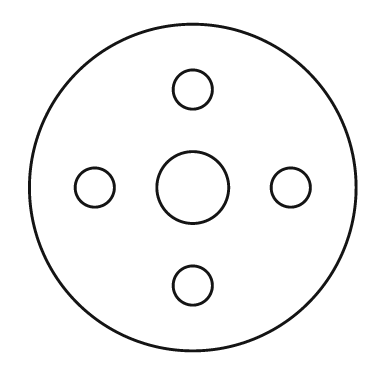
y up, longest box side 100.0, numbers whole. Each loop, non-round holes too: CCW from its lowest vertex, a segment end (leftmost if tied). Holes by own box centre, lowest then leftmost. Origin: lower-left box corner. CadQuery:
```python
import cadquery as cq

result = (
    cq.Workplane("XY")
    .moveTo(50.0, 50.0)
    .circle(50.0)
    .moveTo(50.0, 20.0)
    .circle(6.0)
    .moveTo(20.0, 50.0)
    .circle(6.0)
    .moveTo(50.0, 50.0)
    .circle(11.0)
    .moveTo(80.0, 50.0)
    .circle(6.0)
    .moveTo(50.0, 80.0)
    .circle(6.0)
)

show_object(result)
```